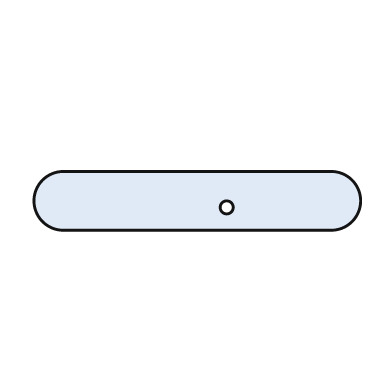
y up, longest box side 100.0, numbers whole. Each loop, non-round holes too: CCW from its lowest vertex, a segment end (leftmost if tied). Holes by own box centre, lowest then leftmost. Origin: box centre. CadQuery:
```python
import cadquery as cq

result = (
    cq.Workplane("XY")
    .moveTo(-41.0, -9.0)
    .lineTo(41.0, -9.0)
    .threePointArc((50.0, 0.0), (41.0, 9.0))
    .lineTo(-41.0, 9.0)
    .threePointArc((-50.0, 0.0), (-41.0, -9.0))
    .close()
    .moveTo(9.0, -2.0)
    .circle(2.0)
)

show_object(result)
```